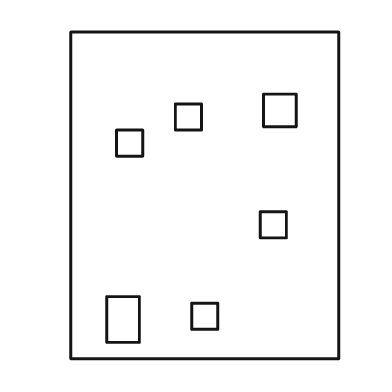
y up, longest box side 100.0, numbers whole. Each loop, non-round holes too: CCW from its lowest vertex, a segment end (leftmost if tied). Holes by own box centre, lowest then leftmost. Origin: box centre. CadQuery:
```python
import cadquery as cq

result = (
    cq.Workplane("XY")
    .moveTo(-41.0, -50.0)
    .lineTo(41.0, -50.0)
    .lineTo(41.0, 50.0)
    .lineTo(-41.0, 50.0)
    .close()
    .moveTo(-30.0, -45.0)
    .lineTo(-20.0, -45.0)
    .lineTo(-20.0, -31.0)
    .lineTo(-30.0, -31.0)
    .close()
    .moveTo(-4.0, -41.0)
    .lineTo(4.0, -41.0)
    .lineTo(4.0, -33.0)
    .lineTo(-4.0, -33.0)
    .close()
    .moveTo(17.0, -13.0)
    .lineTo(25.0, -13.0)
    .lineTo(25.0, -5.0)
    .lineTo(17.0, -5.0)
    .close()
    .moveTo(-27.0, 12.0)
    .lineTo(-19.0, 12.0)
    .lineTo(-19.0, 20.0)
    .lineTo(-27.0, 20.0)
    .close()
    .moveTo(-9.0, 20.0)
    .lineTo(-1.0, 20.0)
    .lineTo(-1.0, 28.0)
    .lineTo(-9.0, 28.0)
    .close()
    .moveTo(18.0, 21.0)
    .lineTo(28.0, 21.0)
    .lineTo(28.0, 31.0)
    .lineTo(18.0, 31.0)
    .close()
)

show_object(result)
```